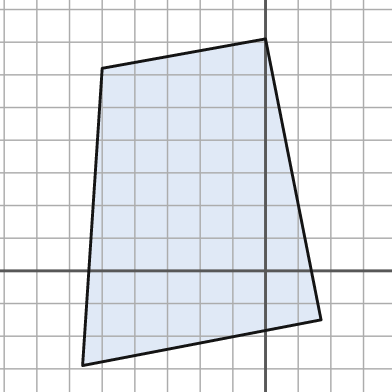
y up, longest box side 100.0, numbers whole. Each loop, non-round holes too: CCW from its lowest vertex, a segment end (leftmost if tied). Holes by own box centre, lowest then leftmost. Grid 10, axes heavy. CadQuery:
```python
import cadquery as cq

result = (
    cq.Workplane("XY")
    .moveTo(-56.0, -29.0)
    .lineTo(17.0, -15.0)
    .lineTo(0.0, 71.0)
    .lineTo(-50.0, 62.0)
    .close()
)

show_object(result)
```